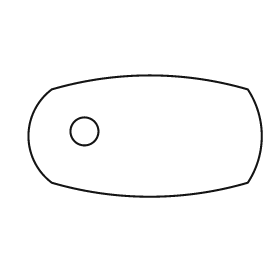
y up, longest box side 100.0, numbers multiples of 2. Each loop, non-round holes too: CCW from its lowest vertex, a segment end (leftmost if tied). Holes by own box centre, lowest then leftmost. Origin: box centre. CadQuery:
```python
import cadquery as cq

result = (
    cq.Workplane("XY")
    .moveTo(-40.0, -20.0)
    .threePointArc((2.0, -26.0), (44.0, -20.0))
    .threePointArc((50.0, 0.0), (44.0, 20.0))
    .threePointArc((2.0, 26.0), (-40.0, 20.0))
    .threePointArc((-50.0, 0.0), (-40.0, -20.0))
    .close()
    .moveTo(-26.0, 2.0)
    .circle(6.0)
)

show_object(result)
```